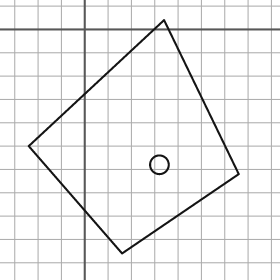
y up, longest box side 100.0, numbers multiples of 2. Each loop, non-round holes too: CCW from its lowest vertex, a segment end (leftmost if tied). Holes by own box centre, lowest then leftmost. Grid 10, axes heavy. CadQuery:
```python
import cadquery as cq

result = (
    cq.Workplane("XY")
    .moveTo(16.0, -96.0)
    .lineTo(66.0, -62.0)
    .lineTo(34.0, 4.0)
    .lineTo(-24.0, -50.0)
    .close()
    .moveTo(32.0, -58.0)
    .circle(4.0)
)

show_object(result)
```